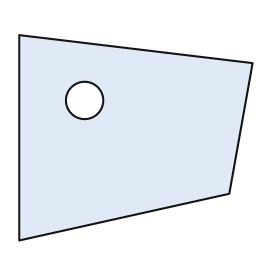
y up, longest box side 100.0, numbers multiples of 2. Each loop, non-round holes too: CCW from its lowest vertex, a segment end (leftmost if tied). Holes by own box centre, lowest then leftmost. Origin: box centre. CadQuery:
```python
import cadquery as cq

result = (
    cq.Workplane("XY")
    .moveTo(-50.0, -44.0)
    .lineTo(40.0, -24.0)
    .lineTo(50.0, 32.0)
    .lineTo(-50.0, 44.0)
    .close()
    .moveTo(-22.0, 16.0)
    .circle(8.0)
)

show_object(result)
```